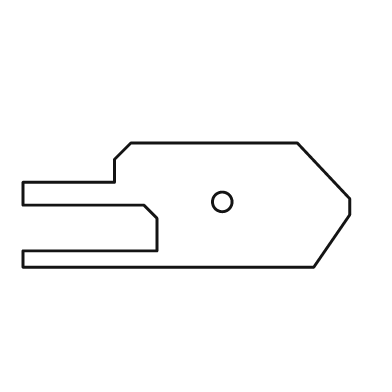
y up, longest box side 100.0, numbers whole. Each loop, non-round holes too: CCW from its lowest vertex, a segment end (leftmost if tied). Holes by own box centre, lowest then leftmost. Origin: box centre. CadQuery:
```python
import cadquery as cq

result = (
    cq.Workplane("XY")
    .moveTo(-50.0, -19.0)
    .lineTo(39.0, -19.0)
    .lineTo(50.0, -3.0)
    .lineTo(50.0, 2.0)
    .lineTo(34.0, 19.0)
    .lineTo(-17.0, 19.0)
    .lineTo(-22.0, 14.0)
    .lineTo(-22.0, 7.0)
    .lineTo(-50.0, 7.0)
    .lineTo(-50.0, 0.0)
    .lineTo(-13.0, 0.0)
    .lineTo(-9.0, -4.0)
    .lineTo(-9.0, -14.0)
    .lineTo(-50.0, -14.0)
    .close()
    .moveTo(11.0, 1.0)
    .circle(3.0)
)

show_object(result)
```